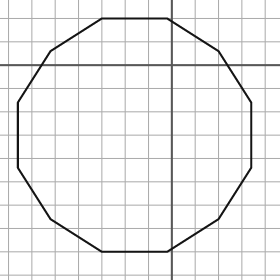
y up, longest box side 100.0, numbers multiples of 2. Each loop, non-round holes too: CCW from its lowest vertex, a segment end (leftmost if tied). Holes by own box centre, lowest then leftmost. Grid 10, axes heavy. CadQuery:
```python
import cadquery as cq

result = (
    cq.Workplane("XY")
    .moveTo(-30.0, -80.0)
    .lineTo(-2.0, -80.0)
    .lineTo(20.0, -66.0)
    .lineTo(34.0, -44.0)
    .lineTo(34.0, -16.0)
    .lineTo(20.0, 6.0)
    .lineTo(-2.0, 20.0)
    .lineTo(-30.0, 20.0)
    .lineTo(-52.0, 6.0)
    .lineTo(-66.0, -16.0)
    .lineTo(-66.0, -44.0)
    .lineTo(-52.0, -66.0)
    .close()
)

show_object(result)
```